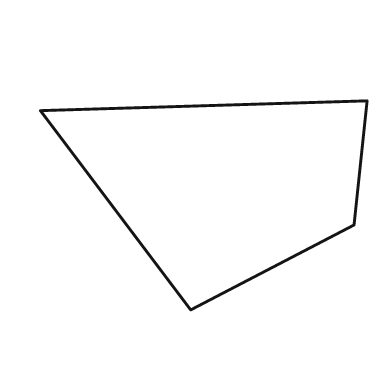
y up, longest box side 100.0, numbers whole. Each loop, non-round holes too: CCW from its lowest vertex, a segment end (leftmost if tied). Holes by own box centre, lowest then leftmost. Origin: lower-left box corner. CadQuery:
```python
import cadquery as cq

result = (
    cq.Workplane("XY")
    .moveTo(46.0, 0.0)
    .lineTo(96.0, 26.0)
    .lineTo(100.0, 64.0)
    .lineTo(0.0, 61.0)
    .close()
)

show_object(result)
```